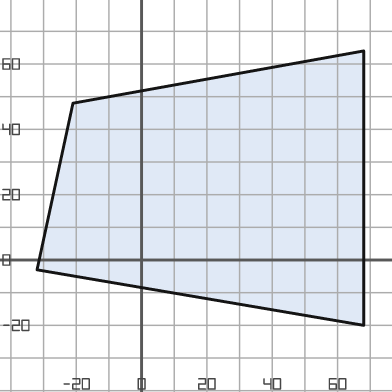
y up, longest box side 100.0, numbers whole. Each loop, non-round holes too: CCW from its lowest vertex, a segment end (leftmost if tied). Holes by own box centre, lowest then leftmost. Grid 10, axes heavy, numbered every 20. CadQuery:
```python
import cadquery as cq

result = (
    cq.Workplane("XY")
    .moveTo(68.0, -20.0)
    .lineTo(68.0, 64.0)
    .lineTo(-21.0, 48.0)
    .lineTo(-32.0, -3.0)
    .close()
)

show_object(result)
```